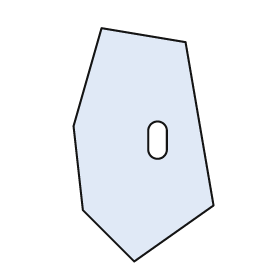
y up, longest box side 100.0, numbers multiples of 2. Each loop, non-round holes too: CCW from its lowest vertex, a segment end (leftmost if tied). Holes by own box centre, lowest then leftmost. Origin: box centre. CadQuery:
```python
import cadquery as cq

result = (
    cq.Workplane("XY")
    .moveTo(-4.0, -50.0)
    .lineTo(30.0, -26.0)
    .lineTo(18.0, 44.0)
    .lineTo(-18.0, 50.0)
    .lineTo(-30.0, 8.0)
    .lineTo(-26.0, -28.0)
    .close()
    .moveTo(2.0, -2.0)
    .threePointArc((6.0, -6.0), (10.0, -2.0))
    .lineTo(10.0, 6.0)
    .threePointArc((6.0, 10.0), (2.0, 6.0))
    .close()
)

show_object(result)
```